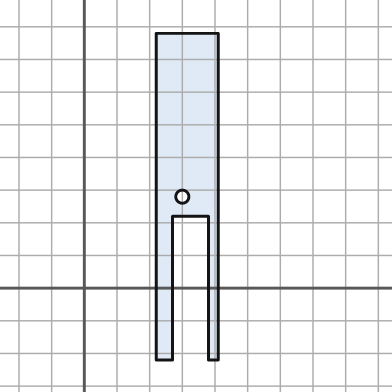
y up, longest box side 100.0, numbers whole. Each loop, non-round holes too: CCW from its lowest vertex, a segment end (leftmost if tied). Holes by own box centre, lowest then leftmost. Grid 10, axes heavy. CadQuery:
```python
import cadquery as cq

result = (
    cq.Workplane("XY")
    .moveTo(22.0, -22.0)
    .lineTo(27.0, -22.0)
    .lineTo(27.0, 22.0)
    .lineTo(38.0, 22.0)
    .lineTo(38.0, -22.0)
    .lineTo(41.0, -22.0)
    .lineTo(41.0, 78.0)
    .lineTo(22.0, 78.0)
    .close()
    .moveTo(30.0, 28.0)
    .circle(2.0)
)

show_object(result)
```